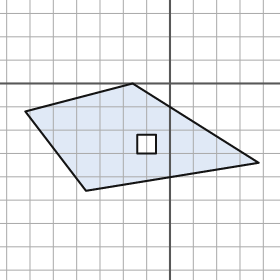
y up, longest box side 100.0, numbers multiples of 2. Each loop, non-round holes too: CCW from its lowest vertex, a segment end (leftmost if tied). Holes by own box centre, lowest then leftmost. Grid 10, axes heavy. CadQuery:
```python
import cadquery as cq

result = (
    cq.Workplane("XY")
    .moveTo(-36.0, -46.0)
    .lineTo(38.0, -34.0)
    .lineTo(-16.0, 0.0)
    .lineTo(-62.0, -12.0)
    .close()
    .moveTo(-14.0, -30.0)
    .lineTo(-6.0, -30.0)
    .lineTo(-6.0, -22.0)
    .lineTo(-14.0, -22.0)
    .close()
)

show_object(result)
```